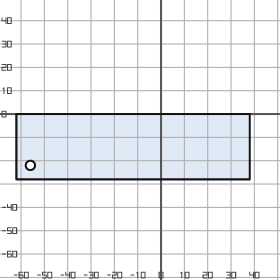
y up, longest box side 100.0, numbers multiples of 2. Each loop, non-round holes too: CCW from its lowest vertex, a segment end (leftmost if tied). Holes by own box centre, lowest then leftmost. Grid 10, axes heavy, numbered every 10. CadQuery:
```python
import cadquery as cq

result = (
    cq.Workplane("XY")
    .moveTo(-62.0, -28.0)
    .lineTo(38.0, -28.0)
    .lineTo(38.0, 0.0)
    .lineTo(-62.0, 0.0)
    .close()
    .moveTo(-56.0, -22.0)
    .circle(2.0)
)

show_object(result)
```